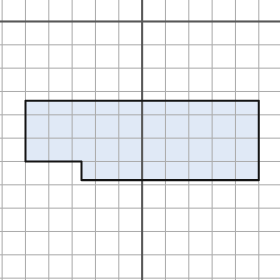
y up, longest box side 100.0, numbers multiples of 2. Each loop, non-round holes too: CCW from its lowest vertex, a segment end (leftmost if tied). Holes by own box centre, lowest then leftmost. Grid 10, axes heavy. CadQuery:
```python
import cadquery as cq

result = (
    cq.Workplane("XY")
    .moveTo(-26.0, -68.0)
    .lineTo(50.0, -68.0)
    .lineTo(50.0, -34.0)
    .lineTo(-50.0, -34.0)
    .lineTo(-50.0, -60.0)
    .lineTo(-26.0, -60.0)
    .close()
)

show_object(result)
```